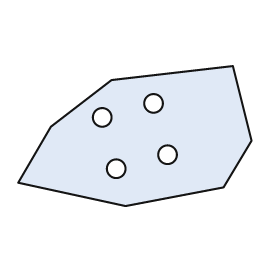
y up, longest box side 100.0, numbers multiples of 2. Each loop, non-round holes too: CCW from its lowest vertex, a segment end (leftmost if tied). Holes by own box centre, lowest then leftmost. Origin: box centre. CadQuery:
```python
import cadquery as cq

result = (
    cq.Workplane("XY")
    .moveTo(-4.0, -30.0)
    .lineTo(38.0, -22.0)
    .lineTo(50.0, -2.0)
    .lineTo(42.0, 30.0)
    .lineTo(-10.0, 24.0)
    .lineTo(-36.0, 4.0)
    .lineTo(-50.0, -20.0)
    .close()
    .moveTo(-8.0, -14.0)
    .circle(4.0)
    .moveTo(14.0, -8.0)
    .circle(4.0)
    .moveTo(-14.0, 8.0)
    .circle(4.0)
    .moveTo(8.0, 14.0)
    .circle(4.0)
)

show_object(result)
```